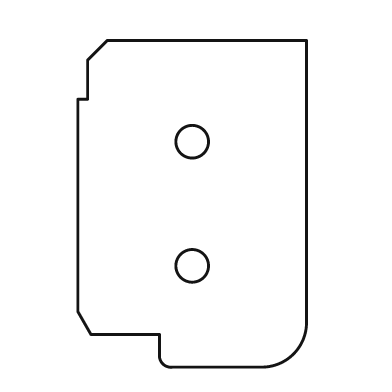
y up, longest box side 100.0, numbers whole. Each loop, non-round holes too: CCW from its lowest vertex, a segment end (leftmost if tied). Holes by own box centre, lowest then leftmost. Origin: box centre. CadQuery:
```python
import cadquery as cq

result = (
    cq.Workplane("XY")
    .moveTo(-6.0, -50.0)
    .lineTo(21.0, -50.0)
    .threePointArc((31.0, -46.0), (35.0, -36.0))
    .lineTo(35.0, 50.0)
    .lineTo(-26.0, 50.0)
    .lineTo(-32.0, 44.0)
    .lineTo(-32.0, 32.0)
    .lineTo(-35.0, 32.0)
    .lineTo(-35.0, -33.0)
    .lineTo(-31.0, -40.0)
    .lineTo(-10.0, -40.0)
    .lineTo(-10.0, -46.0)
    .threePointArc((-9.0, -49.0), (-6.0, -50.0))
    .close()
    .moveTo(0.0, -19.0)
    .circle(5.0)
    .moveTo(0.0, 19.0)
    .circle(5.0)
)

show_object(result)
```